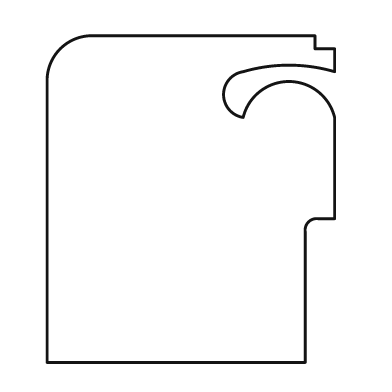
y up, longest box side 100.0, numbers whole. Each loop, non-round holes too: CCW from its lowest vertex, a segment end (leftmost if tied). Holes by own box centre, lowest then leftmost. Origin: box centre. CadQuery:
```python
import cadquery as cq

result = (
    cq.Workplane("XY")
    .moveTo(-44.0, -50.0)
    .lineTo(35.0, -50.0)
    .lineTo(35.0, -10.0)
    .threePointArc((36.0, -7.0), (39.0, -6.0))
    .lineTo(44.0, -6.0)
    .lineTo(44.0, 25.0)
    .threePointArc((30.0, 36.0), (16.0, 25.0))
    .threePointArc((10.0, 32.0), (16.0, 39.0))
    .threePointArc((30.0, 41.0), (44.0, 39.0))
    .lineTo(44.0, 46.0)
    .lineTo(38.0, 46.0)
    .lineTo(38.0, 50.0)
    .lineTo(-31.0, 50.0)
    .threePointArc((-40.0, 46.0), (-44.0, 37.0))
    .close()
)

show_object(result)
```